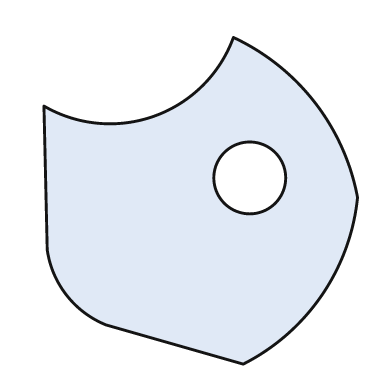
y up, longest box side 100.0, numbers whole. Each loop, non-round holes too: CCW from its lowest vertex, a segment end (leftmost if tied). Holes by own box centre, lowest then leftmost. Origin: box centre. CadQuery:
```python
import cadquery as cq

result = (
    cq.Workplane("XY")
    .moveTo(13.0, -50.0)
    .threePointArc((37.0, -29.0), (48.0, 1.0))
    .threePointArc((35.0, 30.0), (10.0, 50.0))
    .threePointArc((-14.0, 26.0), (-48.0, 29.0))
    .lineTo(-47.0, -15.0)
    .threePointArc((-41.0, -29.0), (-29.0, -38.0))
    .close()
    .moveTo(15.0, 7.0)
    .circle(11.0)
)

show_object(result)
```